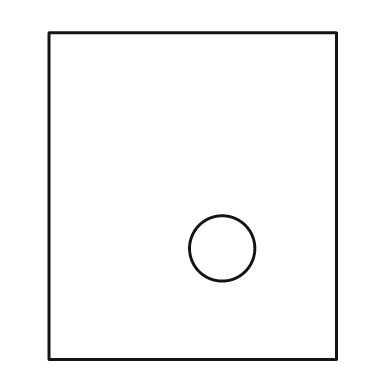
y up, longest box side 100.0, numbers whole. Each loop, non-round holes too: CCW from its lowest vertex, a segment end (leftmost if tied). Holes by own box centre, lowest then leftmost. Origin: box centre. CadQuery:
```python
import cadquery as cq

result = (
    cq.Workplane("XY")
    .moveTo(-44.0, -50.0)
    .lineTo(44.0, -50.0)
    .lineTo(44.0, 50.0)
    .lineTo(-44.0, 50.0)
    .close()
    .moveTo(9.0, -16.0)
    .circle(10.0)
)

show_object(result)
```